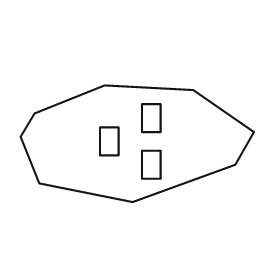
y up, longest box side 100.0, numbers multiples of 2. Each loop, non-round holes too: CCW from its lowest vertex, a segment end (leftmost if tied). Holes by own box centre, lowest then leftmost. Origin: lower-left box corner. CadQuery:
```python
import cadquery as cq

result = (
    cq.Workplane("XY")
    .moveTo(48.0, 0.0)
    .lineTo(92.0, 16.0)
    .lineTo(100.0, 30.0)
    .lineTo(74.0, 48.0)
    .lineTo(36.0, 50.0)
    .lineTo(6.0, 38.0)
    .lineTo(0.0, 28.0)
    .lineTo(8.0, 8.0)
    .close()
    .moveTo(52.0, 10.0)
    .lineTo(60.0, 10.0)
    .lineTo(60.0, 22.0)
    .lineTo(52.0, 22.0)
    .close()
    .moveTo(34.0, 20.0)
    .lineTo(42.0, 20.0)
    .lineTo(42.0, 32.0)
    .lineTo(34.0, 32.0)
    .close()
    .moveTo(52.0, 30.0)
    .lineTo(60.0, 30.0)
    .lineTo(60.0, 42.0)
    .lineTo(52.0, 42.0)
    .close()
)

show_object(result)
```